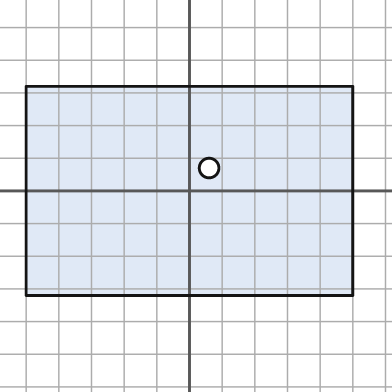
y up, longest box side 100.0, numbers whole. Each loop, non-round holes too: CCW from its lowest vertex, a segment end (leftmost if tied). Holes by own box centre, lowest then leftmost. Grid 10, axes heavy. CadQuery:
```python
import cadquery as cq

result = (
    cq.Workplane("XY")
    .moveTo(-50.0, -32.0)
    .lineTo(50.0, -32.0)
    .lineTo(50.0, 32.0)
    .lineTo(-50.0, 32.0)
    .close()
    .moveTo(6.0, 7.0)
    .circle(3.0)
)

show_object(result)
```